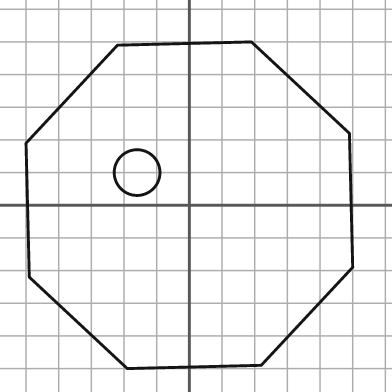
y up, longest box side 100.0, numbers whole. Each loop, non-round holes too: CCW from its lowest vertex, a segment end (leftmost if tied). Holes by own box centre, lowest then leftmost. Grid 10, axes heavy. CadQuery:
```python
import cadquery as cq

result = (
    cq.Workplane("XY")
    .moveTo(-19.0, -50.0)
    .lineTo(22.0, -49.0)
    .lineTo(50.0, -19.0)
    .lineTo(49.0, 22.0)
    .lineTo(19.0, 50.0)
    .lineTo(-22.0, 49.0)
    .lineTo(-50.0, 19.0)
    .lineTo(-49.0, -22.0)
    .close()
    .moveTo(-16.0, 10.0)
    .circle(7.0)
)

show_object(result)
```